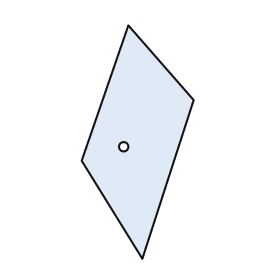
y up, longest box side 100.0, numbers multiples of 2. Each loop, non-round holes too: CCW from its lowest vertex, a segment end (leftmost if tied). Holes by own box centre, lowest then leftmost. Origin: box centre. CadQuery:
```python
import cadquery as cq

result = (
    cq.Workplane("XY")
    .moveTo(2.0, -50.0)
    .lineTo(24.0, 18.0)
    .lineTo(-4.0, 50.0)
    .lineTo(-24.0, -8.0)
    .close()
    .moveTo(-6.0, -2.0)
    .circle(2.0)
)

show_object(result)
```